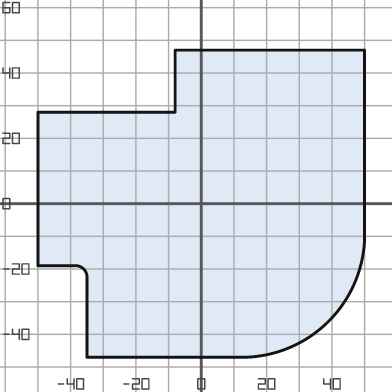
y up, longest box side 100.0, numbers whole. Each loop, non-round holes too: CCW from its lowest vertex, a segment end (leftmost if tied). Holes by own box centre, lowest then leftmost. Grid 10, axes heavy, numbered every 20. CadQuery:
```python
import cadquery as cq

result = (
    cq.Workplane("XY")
    .moveTo(-35.0, -47.0)
    .lineTo(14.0, -47.0)
    .threePointArc((39.0, -36.0), (50.0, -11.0))
    .lineTo(50.0, 47.0)
    .lineTo(-8.0, 47.0)
    .lineTo(-8.0, 28.0)
    .lineTo(-50.0, 28.0)
    .lineTo(-50.0, -19.0)
    .lineTo(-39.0, -19.0)
    .threePointArc((-36.0, -20.0), (-35.0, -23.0))
    .close()
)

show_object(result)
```